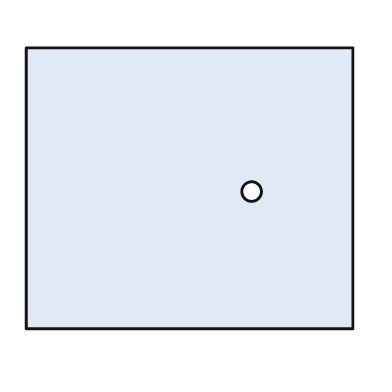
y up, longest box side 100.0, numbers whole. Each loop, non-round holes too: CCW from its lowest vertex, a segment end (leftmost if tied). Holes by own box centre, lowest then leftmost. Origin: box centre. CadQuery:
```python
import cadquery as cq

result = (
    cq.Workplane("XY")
    .moveTo(-50.0, -43.0)
    .lineTo(50.0, -43.0)
    .lineTo(50.0, 43.0)
    .lineTo(-50.0, 43.0)
    .close()
    .moveTo(19.0, -1.0)
    .circle(3.0)
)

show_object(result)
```